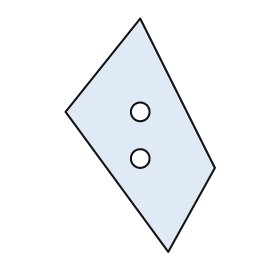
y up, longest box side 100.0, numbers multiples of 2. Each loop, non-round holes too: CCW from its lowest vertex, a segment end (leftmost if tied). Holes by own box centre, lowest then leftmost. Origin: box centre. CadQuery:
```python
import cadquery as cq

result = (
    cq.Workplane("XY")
    .moveTo(12.0, -50.0)
    .lineTo(32.0, -14.0)
    .lineTo(0.0, 50.0)
    .lineTo(-32.0, 10.0)
    .close()
    .moveTo(0.0, -10.0)
    .circle(4.0)
    .moveTo(0.0, 10.0)
    .circle(4.0)
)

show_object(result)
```